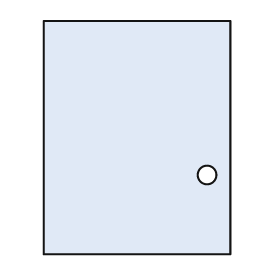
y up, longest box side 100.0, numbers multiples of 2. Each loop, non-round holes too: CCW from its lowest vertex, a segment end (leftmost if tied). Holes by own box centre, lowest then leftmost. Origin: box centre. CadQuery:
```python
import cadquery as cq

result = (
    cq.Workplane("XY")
    .moveTo(-40.0, -50.0)
    .lineTo(40.0, -50.0)
    .lineTo(40.0, 50.0)
    .lineTo(-40.0, 50.0)
    .close()
    .moveTo(30.0, -16.0)
    .circle(4.0)
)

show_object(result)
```